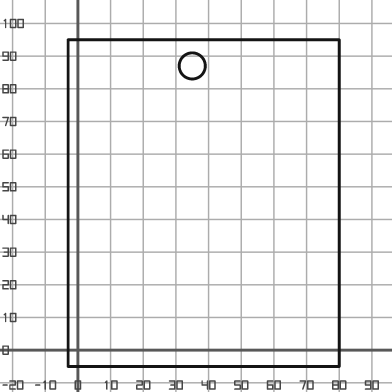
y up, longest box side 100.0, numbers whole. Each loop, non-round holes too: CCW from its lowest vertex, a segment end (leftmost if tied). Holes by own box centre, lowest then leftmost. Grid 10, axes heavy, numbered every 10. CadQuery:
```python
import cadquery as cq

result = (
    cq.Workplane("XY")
    .moveTo(-3.0, -5.0)
    .lineTo(80.0, -5.0)
    .lineTo(80.0, 95.0)
    .lineTo(-3.0, 95.0)
    .close()
    .moveTo(35.0, 87.0)
    .circle(4.0)
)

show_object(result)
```